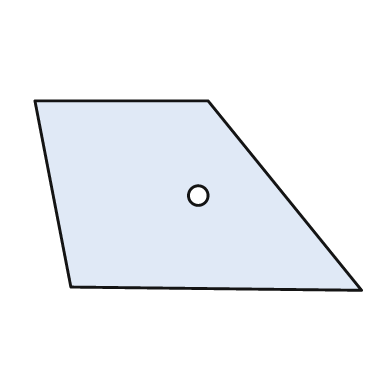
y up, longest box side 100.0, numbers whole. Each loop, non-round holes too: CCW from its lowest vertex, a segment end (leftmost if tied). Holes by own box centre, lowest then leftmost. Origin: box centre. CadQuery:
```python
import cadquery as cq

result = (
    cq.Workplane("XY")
    .moveTo(50.0, -29.0)
    .lineTo(3.0, 29.0)
    .lineTo(-50.0, 29.0)
    .lineTo(-39.0, -28.0)
    .close()
    .moveTo(0.0, 0.0)
    .circle(3.0)
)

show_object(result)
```